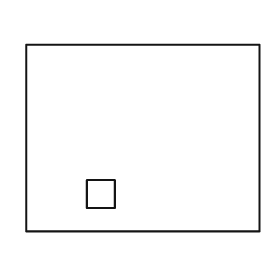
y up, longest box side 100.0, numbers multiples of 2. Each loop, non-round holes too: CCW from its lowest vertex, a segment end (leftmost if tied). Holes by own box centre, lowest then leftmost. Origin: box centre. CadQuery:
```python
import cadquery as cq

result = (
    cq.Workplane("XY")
    .moveTo(-50.0, -40.0)
    .lineTo(50.0, -40.0)
    .lineTo(50.0, 40.0)
    .lineTo(-50.0, 40.0)
    .close()
    .moveTo(-24.0, -30.0)
    .lineTo(-12.0, -30.0)
    .lineTo(-12.0, -18.0)
    .lineTo(-24.0, -18.0)
    .close()
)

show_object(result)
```